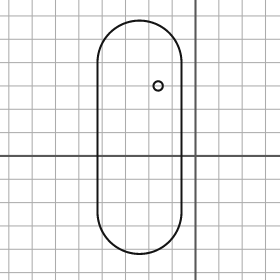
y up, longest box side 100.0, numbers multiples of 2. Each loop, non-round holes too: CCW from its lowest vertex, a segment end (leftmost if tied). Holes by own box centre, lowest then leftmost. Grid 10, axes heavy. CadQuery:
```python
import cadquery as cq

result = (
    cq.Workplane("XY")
    .moveTo(-42.0, -24.0)
    .threePointArc((-24.0, -42.0), (-6.0, -24.0))
    .lineTo(-6.0, 40.0)
    .threePointArc((-24.0, 58.0), (-42.0, 40.0))
    .close()
    .moveTo(-16.0, 30.0)
    .circle(2.0)
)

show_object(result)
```